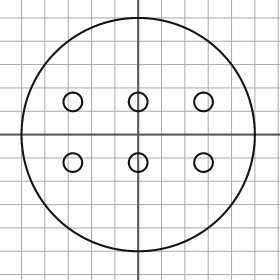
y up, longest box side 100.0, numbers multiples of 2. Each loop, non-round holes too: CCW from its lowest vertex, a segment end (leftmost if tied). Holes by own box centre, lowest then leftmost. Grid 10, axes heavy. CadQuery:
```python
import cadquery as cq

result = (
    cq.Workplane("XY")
    .moveTo(0.0, 0.0)
    .circle(50.0)
    .moveTo(-28.0, -12.0)
    .circle(4.0)
    .moveTo(0.0, -12.0)
    .circle(4.0)
    .moveTo(28.0, -12.0)
    .circle(4.0)
    .moveTo(-28.0, 14.0)
    .circle(4.0)
    .moveTo(0.0, 14.0)
    .circle(4.0)
    .moveTo(28.0, 14.0)
    .circle(4.0)
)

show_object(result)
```